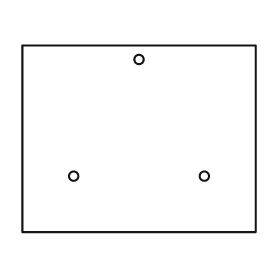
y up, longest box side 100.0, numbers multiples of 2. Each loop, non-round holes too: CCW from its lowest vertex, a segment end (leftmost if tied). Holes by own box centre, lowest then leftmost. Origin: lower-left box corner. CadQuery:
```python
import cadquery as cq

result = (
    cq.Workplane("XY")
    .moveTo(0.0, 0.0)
    .lineTo(100.0, 0.0)
    .lineTo(100.0, 80.0)
    .lineTo(0.0, 80.0)
    .close()
    .moveTo(22.0, 24.0)
    .circle(2.0)
    .moveTo(78.0, 24.0)
    .circle(2.0)
    .moveTo(50.0, 74.0)
    .circle(2.0)
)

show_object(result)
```